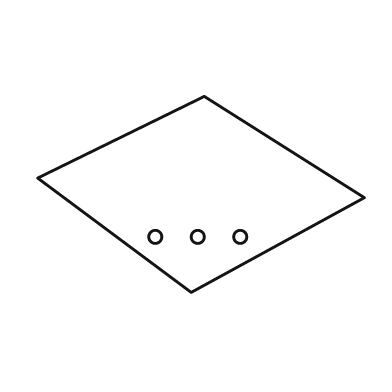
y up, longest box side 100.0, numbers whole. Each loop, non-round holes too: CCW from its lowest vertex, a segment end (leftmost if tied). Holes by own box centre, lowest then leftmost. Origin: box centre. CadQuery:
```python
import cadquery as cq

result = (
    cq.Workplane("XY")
    .moveTo(-3.0, -30.0)
    .lineTo(50.0, -1.0)
    .lineTo(1.0, 30.0)
    .lineTo(-50.0, 5.0)
    .close()
    .moveTo(-14.0, -13.0)
    .circle(2.0)
    .moveTo(-1.0, -13.0)
    .circle(2.0)
    .moveTo(12.0, -13.0)
    .circle(2.0)
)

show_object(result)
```